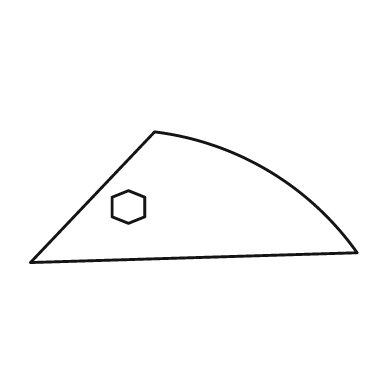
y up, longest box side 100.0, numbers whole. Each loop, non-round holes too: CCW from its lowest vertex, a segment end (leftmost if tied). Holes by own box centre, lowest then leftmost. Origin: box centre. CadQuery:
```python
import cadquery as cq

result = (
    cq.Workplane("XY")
    .moveTo(-50.0, -20.0)
    .lineTo(50.0, -17.0)
    .threePointArc((23.0, 8.0), (-12.0, 20.0))
    .close()
    .moveTo(-20.0, -8.0)
    .lineTo(-15.0, -6.0)
    .lineTo(-15.0, 0.0)
    .lineTo(-20.0, 2.0)
    .lineTo(-25.0, 0.0)
    .lineTo(-25.0, -6.0)
    .close()
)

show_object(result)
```